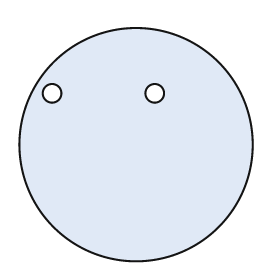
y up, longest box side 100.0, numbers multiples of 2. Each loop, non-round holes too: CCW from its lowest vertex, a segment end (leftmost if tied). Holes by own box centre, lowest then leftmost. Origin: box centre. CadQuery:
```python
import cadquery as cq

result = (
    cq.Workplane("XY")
    .moveTo(0.0, 0.0)
    .circle(50.0)
    .moveTo(-36.0, 22.0)
    .circle(4.0)
    .moveTo(8.0, 22.0)
    .circle(4.0)
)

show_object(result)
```